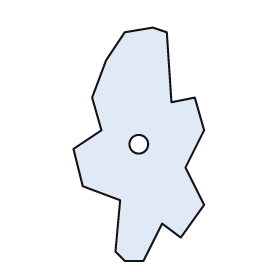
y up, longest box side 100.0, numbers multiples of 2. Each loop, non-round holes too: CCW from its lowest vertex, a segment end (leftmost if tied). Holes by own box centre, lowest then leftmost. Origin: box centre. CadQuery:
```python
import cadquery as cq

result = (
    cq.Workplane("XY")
    .moveTo(-6.0, -50.0)
    .lineTo(2.0, -50.0)
    .lineTo(10.0, -34.0)
    .lineTo(18.0, -40.0)
    .lineTo(28.0, -26.0)
    .lineTo(20.0, -10.0)
    .lineTo(28.0, 6.0)
    .lineTo(24.0, 20.0)
    .lineTo(14.0, 18.0)
    .lineTo(12.0, 48.0)
    .lineTo(6.0, 50.0)
    .lineTo(-6.0, 48.0)
    .lineTo(-14.0, 36.0)
    .lineTo(-20.0, 20.0)
    .lineTo(-16.0, 6.0)
    .lineTo(-28.0, -2.0)
    .lineTo(-24.0, -18.0)
    .lineTo(-8.0, -24.0)
    .lineTo(-10.0, -46.0)
    .close()
    .moveTo(0.0, 0.0)
    .circle(4.0)
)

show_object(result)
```